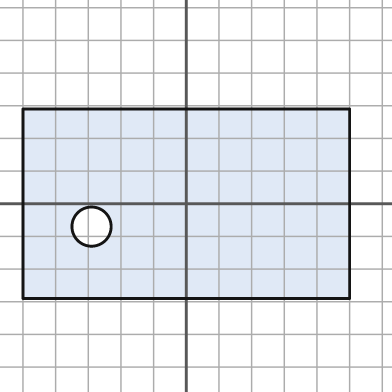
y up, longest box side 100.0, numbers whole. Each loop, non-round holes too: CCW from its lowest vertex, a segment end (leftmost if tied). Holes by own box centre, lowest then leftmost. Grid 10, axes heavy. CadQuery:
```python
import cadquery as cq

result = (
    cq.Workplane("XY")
    .moveTo(-50.0, -29.0)
    .lineTo(50.0, -29.0)
    .lineTo(50.0, 29.0)
    .lineTo(-50.0, 29.0)
    .close()
    .moveTo(-29.0, -7.0)
    .circle(6.0)
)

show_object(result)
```